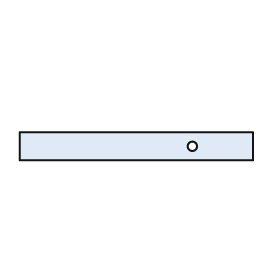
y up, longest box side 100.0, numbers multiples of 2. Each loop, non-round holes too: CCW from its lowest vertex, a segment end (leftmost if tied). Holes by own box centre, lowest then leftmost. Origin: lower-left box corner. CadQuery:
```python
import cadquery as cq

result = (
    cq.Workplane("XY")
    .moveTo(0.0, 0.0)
    .lineTo(100.0, 0.0)
    .lineTo(100.0, 12.0)
    .lineTo(0.0, 12.0)
    .close()
    .moveTo(74.0, 6.0)
    .circle(2.0)
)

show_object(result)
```